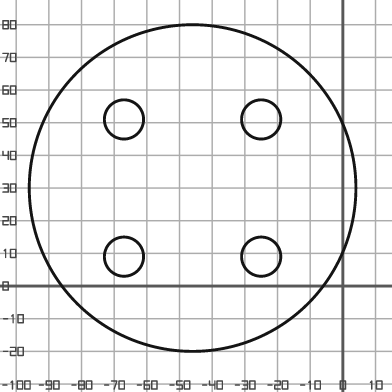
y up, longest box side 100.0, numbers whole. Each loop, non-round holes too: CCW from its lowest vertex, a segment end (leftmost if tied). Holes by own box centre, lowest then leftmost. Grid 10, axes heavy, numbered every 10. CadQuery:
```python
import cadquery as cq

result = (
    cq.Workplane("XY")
    .moveTo(-46.0, 30.0)
    .circle(50.0)
    .moveTo(-67.0, 9.0)
    .circle(6.0)
    .moveTo(-25.0, 9.0)
    .circle(6.0)
    .moveTo(-67.0, 51.0)
    .circle(6.0)
    .moveTo(-25.0, 51.0)
    .circle(6.0)
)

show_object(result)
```